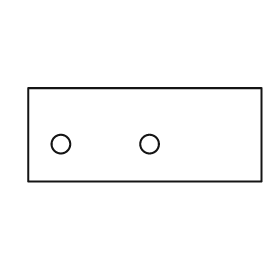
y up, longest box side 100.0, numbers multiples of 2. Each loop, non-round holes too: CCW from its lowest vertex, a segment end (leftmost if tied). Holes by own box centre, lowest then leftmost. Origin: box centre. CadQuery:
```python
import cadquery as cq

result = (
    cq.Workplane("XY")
    .moveTo(-50.0, -20.0)
    .lineTo(50.0, -20.0)
    .lineTo(50.0, 20.0)
    .lineTo(-50.0, 20.0)
    .close()
    .moveTo(-36.0, -4.0)
    .circle(4.0)
    .moveTo(2.0, -4.0)
    .circle(4.0)
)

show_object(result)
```